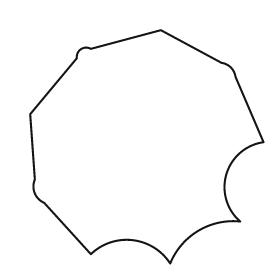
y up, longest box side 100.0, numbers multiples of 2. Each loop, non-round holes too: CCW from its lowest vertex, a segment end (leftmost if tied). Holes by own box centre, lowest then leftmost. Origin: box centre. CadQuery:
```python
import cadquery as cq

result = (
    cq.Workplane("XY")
    .moveTo(10.0, -50.0)
    .threePointArc((22.0, -36.0), (40.0, -32.0))
    .threePointArc((34.0, -12.0), (50.0, 2.0))
    .lineTo(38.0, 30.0)
    .threePointArc((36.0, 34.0), (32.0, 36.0))
    .lineTo(6.0, 50.0)
    .lineTo(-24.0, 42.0)
    .threePointArc((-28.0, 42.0), (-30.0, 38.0))
    .lineTo(-50.0, 14.0)
    .lineTo(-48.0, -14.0)
    .threePointArc((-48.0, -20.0), (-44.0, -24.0))
    .lineTo(-24.0, -46.0)
    .threePointArc((-6.0, -40.0), (10.0, -50.0))
    .close()
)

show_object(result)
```